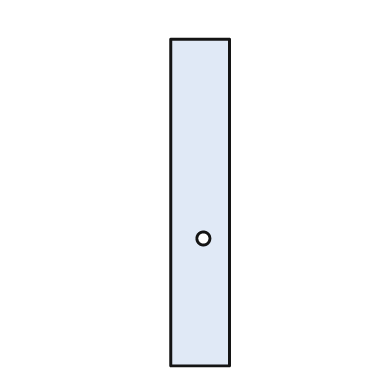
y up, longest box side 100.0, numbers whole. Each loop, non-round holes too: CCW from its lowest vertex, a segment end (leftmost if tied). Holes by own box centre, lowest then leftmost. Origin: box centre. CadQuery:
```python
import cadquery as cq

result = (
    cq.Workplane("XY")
    .moveTo(-9.0, -50.0)
    .lineTo(9.0, -50.0)
    .lineTo(9.0, 50.0)
    .lineTo(-9.0, 50.0)
    .close()
    .moveTo(1.0, -11.0)
    .circle(2.0)
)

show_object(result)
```